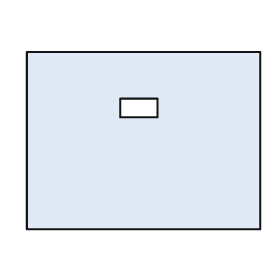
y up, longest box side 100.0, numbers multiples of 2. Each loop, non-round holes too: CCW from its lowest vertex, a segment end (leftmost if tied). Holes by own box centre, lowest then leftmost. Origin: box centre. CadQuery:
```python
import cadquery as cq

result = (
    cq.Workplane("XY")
    .moveTo(-50.0, -38.0)
    .lineTo(50.0, -38.0)
    .lineTo(50.0, 38.0)
    .lineTo(-50.0, 38.0)
    .close()
    .moveTo(-10.0, 10.0)
    .lineTo(6.0, 10.0)
    .lineTo(6.0, 18.0)
    .lineTo(-10.0, 18.0)
    .close()
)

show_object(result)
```